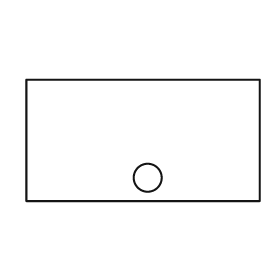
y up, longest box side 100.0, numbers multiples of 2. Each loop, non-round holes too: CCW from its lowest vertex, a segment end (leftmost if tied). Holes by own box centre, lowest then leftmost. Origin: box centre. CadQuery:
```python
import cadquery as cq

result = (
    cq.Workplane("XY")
    .moveTo(-50.0, -26.0)
    .lineTo(50.0, -26.0)
    .lineTo(50.0, 26.0)
    .lineTo(-50.0, 26.0)
    .close()
    .moveTo(2.0, -16.0)
    .circle(6.0)
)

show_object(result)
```